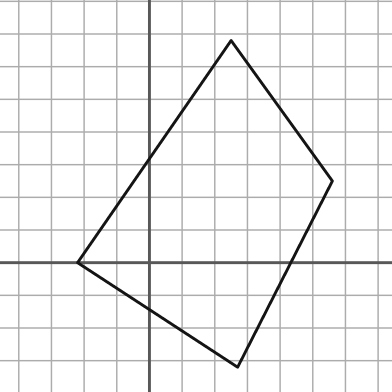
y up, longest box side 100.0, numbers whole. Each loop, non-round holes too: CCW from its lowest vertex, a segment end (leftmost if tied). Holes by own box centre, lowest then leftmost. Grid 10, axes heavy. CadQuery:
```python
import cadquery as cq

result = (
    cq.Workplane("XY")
    .moveTo(27.0, -32.0)
    .lineTo(56.0, 25.0)
    .lineTo(25.0, 68.0)
    .lineTo(-22.0, 0.0)
    .close()
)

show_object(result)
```